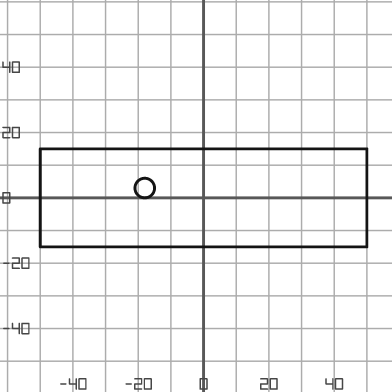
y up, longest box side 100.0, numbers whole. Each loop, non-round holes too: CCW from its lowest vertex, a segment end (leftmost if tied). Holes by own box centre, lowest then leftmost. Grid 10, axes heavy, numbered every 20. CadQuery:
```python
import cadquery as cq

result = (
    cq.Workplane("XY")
    .moveTo(-50.0, -15.0)
    .lineTo(50.0, -15.0)
    .lineTo(50.0, 15.0)
    .lineTo(-50.0, 15.0)
    .close()
    .moveTo(-18.0, 3.0)
    .circle(3.0)
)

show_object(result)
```